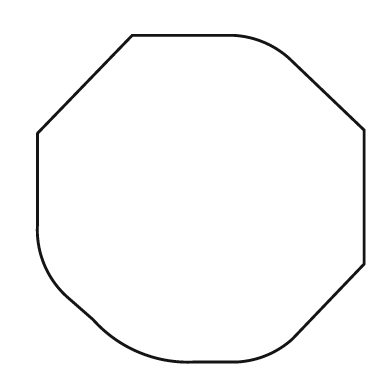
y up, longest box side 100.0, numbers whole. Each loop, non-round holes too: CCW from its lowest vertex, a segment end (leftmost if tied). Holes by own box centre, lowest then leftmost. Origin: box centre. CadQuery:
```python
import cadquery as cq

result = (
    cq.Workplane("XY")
    .moveTo(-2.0, -50.0)
    .lineTo(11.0, -50.0)
    .threePointArc((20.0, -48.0), (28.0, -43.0))
    .lineTo(50.0, -20.0)
    .lineTo(50.0, 21.0)
    .lineTo(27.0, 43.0)
    .threePointArc((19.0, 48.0), (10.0, 50.0))
    .lineTo(-21.0, 50.0)
    .lineTo(-50.0, 20.0)
    .lineTo(-50.0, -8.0)
    .threePointArc((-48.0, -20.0), (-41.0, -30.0))
    .lineTo(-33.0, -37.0)
    .threePointArc((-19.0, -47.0), (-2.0, -50.0))
    .close()
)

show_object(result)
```